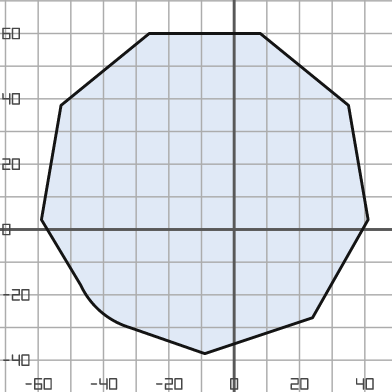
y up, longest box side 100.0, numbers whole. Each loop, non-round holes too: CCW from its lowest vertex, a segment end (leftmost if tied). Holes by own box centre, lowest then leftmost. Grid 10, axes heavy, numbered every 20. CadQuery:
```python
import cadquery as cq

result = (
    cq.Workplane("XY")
    .moveTo(-9.0, -38.0)
    .lineTo(24.0, -27.0)
    .lineTo(41.0, 3.0)
    .lineTo(35.0, 38.0)
    .lineTo(8.0, 60.0)
    .lineTo(-26.0, 60.0)
    .lineTo(-53.0, 38.0)
    .lineTo(-59.0, 3.0)
    .lineTo(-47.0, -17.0)
    .threePointArc((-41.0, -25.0), (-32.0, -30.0))
    .close()
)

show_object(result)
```